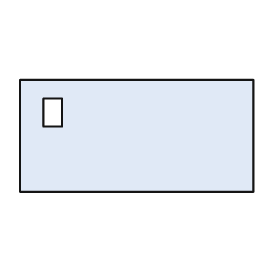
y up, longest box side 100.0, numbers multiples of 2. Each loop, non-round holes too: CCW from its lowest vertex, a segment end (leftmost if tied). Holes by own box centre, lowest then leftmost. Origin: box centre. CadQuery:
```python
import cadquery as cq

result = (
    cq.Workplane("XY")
    .moveTo(-50.0, -24.0)
    .lineTo(50.0, -24.0)
    .lineTo(50.0, 24.0)
    .lineTo(-50.0, 24.0)
    .close()
    .moveTo(-40.0, 4.0)
    .lineTo(-32.0, 4.0)
    .lineTo(-32.0, 16.0)
    .lineTo(-40.0, 16.0)
    .close()
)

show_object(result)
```